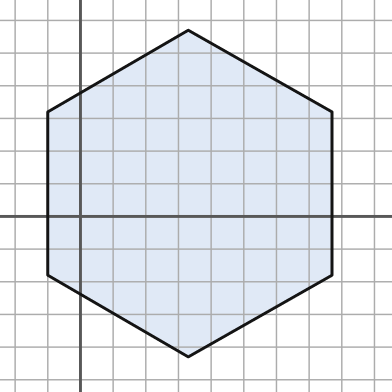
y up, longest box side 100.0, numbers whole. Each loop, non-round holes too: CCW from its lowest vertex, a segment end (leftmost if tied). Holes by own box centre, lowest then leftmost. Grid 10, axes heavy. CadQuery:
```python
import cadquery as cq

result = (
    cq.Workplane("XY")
    .moveTo(33.0, -43.0)
    .lineTo(77.0, -18.0)
    .lineTo(77.0, 32.0)
    .lineTo(33.0, 57.0)
    .lineTo(-10.0, 32.0)
    .lineTo(-10.0, -18.0)
    .close()
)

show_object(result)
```